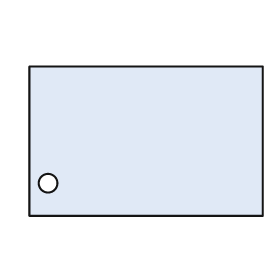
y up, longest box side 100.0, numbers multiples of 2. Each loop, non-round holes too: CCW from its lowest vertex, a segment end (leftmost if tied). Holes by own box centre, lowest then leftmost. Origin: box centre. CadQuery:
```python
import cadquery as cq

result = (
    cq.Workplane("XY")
    .moveTo(-50.0, -32.0)
    .lineTo(50.0, -32.0)
    .lineTo(50.0, 32.0)
    .lineTo(-50.0, 32.0)
    .close()
    .moveTo(-42.0, -18.0)
    .circle(4.0)
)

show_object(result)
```